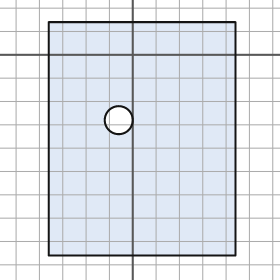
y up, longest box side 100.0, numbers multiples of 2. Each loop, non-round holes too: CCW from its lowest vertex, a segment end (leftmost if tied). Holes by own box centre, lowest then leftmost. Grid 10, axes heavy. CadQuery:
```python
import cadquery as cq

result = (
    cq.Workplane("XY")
    .moveTo(-36.0, -86.0)
    .lineTo(44.0, -86.0)
    .lineTo(44.0, 14.0)
    .lineTo(-36.0, 14.0)
    .close()
    .moveTo(-6.0, -28.0)
    .circle(6.0)
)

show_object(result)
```